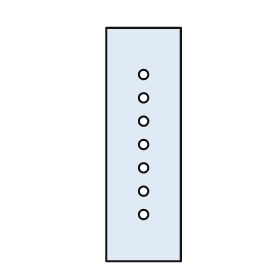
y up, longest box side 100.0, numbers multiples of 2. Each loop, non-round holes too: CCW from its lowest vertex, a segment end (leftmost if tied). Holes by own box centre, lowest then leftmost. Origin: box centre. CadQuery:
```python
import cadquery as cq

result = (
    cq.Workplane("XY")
    .moveTo(-16.0, -50.0)
    .lineTo(16.0, -50.0)
    .lineTo(16.0, 50.0)
    .lineTo(-16.0, 50.0)
    .close()
    .moveTo(0.0, -30.0)
    .circle(2.0)
    .moveTo(0.0, -20.0)
    .circle(2.0)
    .moveTo(0.0, -10.0)
    .circle(2.0)
    .moveTo(0.0, 0.0)
    .circle(2.0)
    .moveTo(0.0, 10.0)
    .circle(2.0)
    .moveTo(0.0, 20.0)
    .circle(2.0)
    .moveTo(0.0, 30.0)
    .circle(2.0)
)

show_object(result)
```